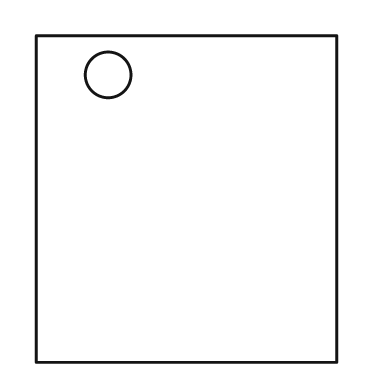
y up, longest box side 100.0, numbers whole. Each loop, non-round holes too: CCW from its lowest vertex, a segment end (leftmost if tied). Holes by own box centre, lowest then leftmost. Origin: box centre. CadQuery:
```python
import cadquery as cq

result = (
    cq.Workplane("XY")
    .moveTo(-46.0, -50.0)
    .lineTo(46.0, -50.0)
    .lineTo(46.0, 50.0)
    .lineTo(-46.0, 50.0)
    .close()
    .moveTo(-24.0, 38.0)
    .circle(7.0)
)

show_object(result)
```